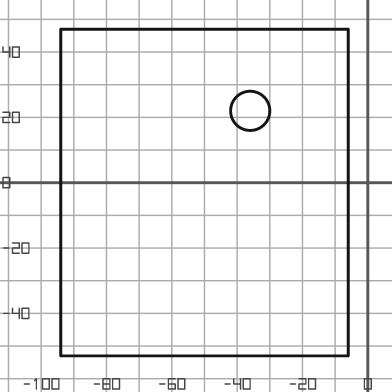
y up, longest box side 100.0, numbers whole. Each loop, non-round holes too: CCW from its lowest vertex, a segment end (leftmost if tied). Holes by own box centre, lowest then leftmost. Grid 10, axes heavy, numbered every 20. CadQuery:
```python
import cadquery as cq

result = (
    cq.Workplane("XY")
    .moveTo(-94.0, -53.0)
    .lineTo(-6.0, -53.0)
    .lineTo(-6.0, 47.0)
    .lineTo(-94.0, 47.0)
    .close()
    .moveTo(-36.0, 22.0)
    .circle(6.0)
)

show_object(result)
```